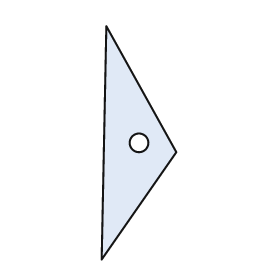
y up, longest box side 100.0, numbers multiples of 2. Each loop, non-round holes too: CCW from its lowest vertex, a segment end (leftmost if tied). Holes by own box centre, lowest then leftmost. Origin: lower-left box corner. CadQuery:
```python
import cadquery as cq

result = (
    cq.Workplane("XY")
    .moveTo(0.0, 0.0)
    .lineTo(32.0, 46.0)
    .lineTo(2.0, 100.0)
    .close()
    .moveTo(16.0, 50.0)
    .circle(4.0)
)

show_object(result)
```